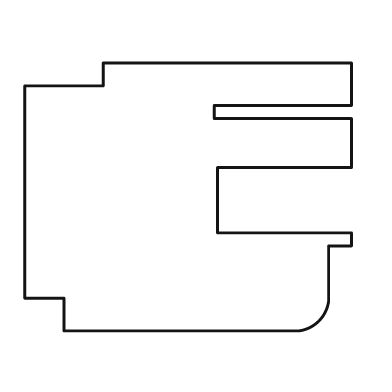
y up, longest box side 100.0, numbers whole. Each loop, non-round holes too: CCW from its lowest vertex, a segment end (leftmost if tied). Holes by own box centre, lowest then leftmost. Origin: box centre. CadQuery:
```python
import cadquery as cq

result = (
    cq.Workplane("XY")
    .moveTo(-38.0, -41.0)
    .lineTo(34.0, -41.0)
    .threePointArc((40.0, -38.0), (43.0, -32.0))
    .lineTo(43.0, -15.0)
    .lineTo(50.0, -15.0)
    .lineTo(50.0, -11.0)
    .lineTo(9.0, -11.0)
    .lineTo(9.0, 9.0)
    .lineTo(50.0, 9.0)
    .lineTo(50.0, 24.0)
    .lineTo(8.0, 24.0)
    .lineTo(8.0, 28.0)
    .lineTo(50.0, 28.0)
    .lineTo(50.0, 41.0)
    .lineTo(-26.0, 41.0)
    .lineTo(-26.0, 34.0)
    .lineTo(-50.0, 34.0)
    .lineTo(-50.0, -31.0)
    .lineTo(-38.0, -31.0)
    .close()
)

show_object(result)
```